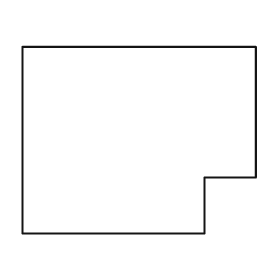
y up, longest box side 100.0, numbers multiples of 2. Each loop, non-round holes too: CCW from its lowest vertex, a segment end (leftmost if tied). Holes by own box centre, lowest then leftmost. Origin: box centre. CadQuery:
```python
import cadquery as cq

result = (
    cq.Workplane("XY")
    .moveTo(-50.0, -40.0)
    .lineTo(28.0, -40.0)
    .lineTo(28.0, -16.0)
    .lineTo(50.0, -16.0)
    .lineTo(50.0, 40.0)
    .lineTo(-50.0, 40.0)
    .close()
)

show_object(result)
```